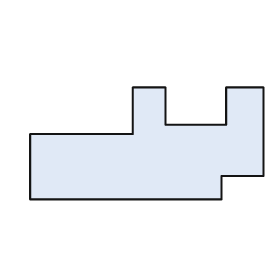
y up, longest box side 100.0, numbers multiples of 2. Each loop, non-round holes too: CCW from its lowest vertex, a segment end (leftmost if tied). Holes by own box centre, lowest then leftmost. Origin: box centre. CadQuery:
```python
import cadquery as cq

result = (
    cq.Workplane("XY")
    .moveTo(-50.0, -24.0)
    .lineTo(32.0, -24.0)
    .lineTo(32.0, -14.0)
    .lineTo(50.0, -14.0)
    .lineTo(50.0, 24.0)
    .lineTo(34.0, 24.0)
    .lineTo(34.0, 8.0)
    .lineTo(8.0, 8.0)
    .lineTo(8.0, 24.0)
    .lineTo(-6.0, 24.0)
    .lineTo(-6.0, 4.0)
    .lineTo(-50.0, 4.0)
    .close()
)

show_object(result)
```